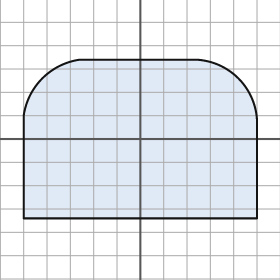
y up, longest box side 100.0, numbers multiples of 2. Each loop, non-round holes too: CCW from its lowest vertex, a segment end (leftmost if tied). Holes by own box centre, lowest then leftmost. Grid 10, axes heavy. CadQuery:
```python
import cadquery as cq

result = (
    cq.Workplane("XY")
    .moveTo(-50.0, -34.0)
    .lineTo(50.0, -34.0)
    .lineTo(50.0, 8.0)
    .threePointArc((42.0, 26.0), (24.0, 34.0))
    .lineTo(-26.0, 34.0)
    .threePointArc((-42.0, 26.0), (-50.0, 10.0))
    .close()
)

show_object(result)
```